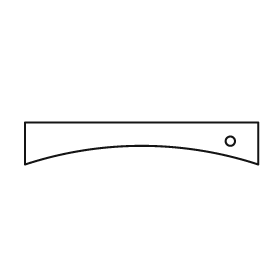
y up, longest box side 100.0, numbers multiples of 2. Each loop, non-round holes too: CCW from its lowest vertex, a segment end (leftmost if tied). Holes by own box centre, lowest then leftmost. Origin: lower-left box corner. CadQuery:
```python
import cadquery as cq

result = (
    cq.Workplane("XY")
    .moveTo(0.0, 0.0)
    .threePointArc((50.0, 8.0), (100.0, 0.0))
    .lineTo(100.0, 18.0)
    .lineTo(0.0, 18.0)
    .close()
    .moveTo(88.0, 10.0)
    .circle(2.0)
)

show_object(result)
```